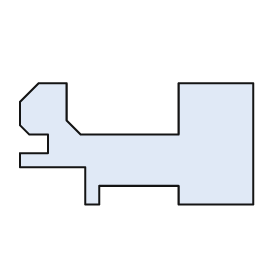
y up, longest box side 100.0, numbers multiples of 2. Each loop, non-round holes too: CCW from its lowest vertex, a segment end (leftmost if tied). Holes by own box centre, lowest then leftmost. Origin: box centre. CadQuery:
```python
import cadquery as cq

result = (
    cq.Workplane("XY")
    .moveTo(-22.0, -26.0)
    .lineTo(-16.0, -26.0)
    .lineTo(-16.0, -18.0)
    .lineTo(18.0, -18.0)
    .lineTo(18.0, -26.0)
    .lineTo(50.0, -26.0)
    .lineTo(50.0, 26.0)
    .lineTo(18.0, 26.0)
    .lineTo(18.0, 4.0)
    .lineTo(-24.0, 4.0)
    .lineTo(-30.0, 10.0)
    .lineTo(-30.0, 26.0)
    .lineTo(-42.0, 26.0)
    .lineTo(-50.0, 18.0)
    .lineTo(-50.0, 8.0)
    .lineTo(-46.0, 4.0)
    .lineTo(-38.0, 4.0)
    .lineTo(-38.0, -4.0)
    .lineTo(-50.0, -4.0)
    .lineTo(-50.0, -10.0)
    .lineTo(-22.0, -10.0)
    .close()
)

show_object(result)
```